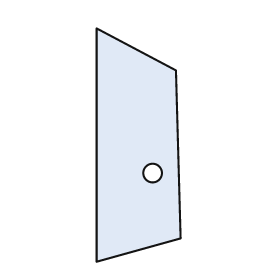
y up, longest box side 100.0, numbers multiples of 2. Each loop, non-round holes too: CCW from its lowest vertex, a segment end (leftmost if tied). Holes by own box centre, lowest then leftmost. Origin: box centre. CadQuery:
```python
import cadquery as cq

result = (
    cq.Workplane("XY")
    .moveTo(-18.0, -50.0)
    .lineTo(18.0, -40.0)
    .lineTo(16.0, 32.0)
    .lineTo(-18.0, 50.0)
    .close()
    .moveTo(6.0, -12.0)
    .circle(4.0)
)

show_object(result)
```